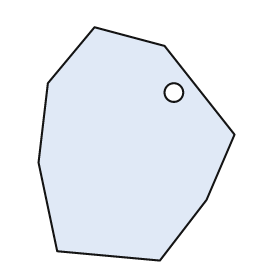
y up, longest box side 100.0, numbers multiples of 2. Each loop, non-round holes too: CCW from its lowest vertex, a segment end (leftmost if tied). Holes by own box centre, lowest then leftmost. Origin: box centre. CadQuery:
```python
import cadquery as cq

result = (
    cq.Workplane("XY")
    .moveTo(10.0, -50.0)
    .lineTo(30.0, -24.0)
    .lineTo(42.0, 4.0)
    .lineTo(12.0, 42.0)
    .lineTo(-18.0, 50.0)
    .lineTo(-38.0, 26.0)
    .lineTo(-42.0, -8.0)
    .lineTo(-34.0, -46.0)
    .close()
    .moveTo(16.0, 22.0)
    .circle(4.0)
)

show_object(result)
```